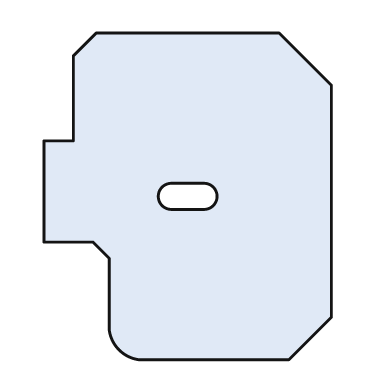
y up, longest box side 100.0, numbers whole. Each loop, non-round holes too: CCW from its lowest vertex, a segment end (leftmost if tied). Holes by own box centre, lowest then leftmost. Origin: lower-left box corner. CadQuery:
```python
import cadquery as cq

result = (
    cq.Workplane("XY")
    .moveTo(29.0, 0.0)
    .lineTo(75.0, 0.0)
    .lineTo(88.0, 13.0)
    .lineTo(88.0, 84.0)
    .lineTo(72.0, 100.0)
    .lineTo(16.0, 100.0)
    .lineTo(9.0, 93.0)
    .lineTo(9.0, 67.0)
    .lineTo(0.0, 67.0)
    .lineTo(0.0, 36.0)
    .lineTo(15.0, 36.0)
    .lineTo(20.0, 31.0)
    .lineTo(20.0, 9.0)
    .threePointArc((23.0, 3.0), (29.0, 0.0))
    .close()
    .moveTo(39.0, 46.0)
    .lineTo(49.0, 46.0)
    .threePointArc((53.0, 50.0), (49.0, 54.0))
    .lineTo(39.0, 54.0)
    .threePointArc((35.0, 50.0), (39.0, 46.0))
    .close()
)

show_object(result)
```